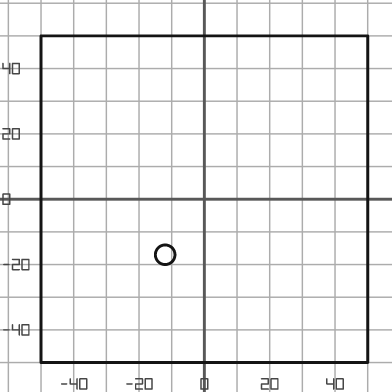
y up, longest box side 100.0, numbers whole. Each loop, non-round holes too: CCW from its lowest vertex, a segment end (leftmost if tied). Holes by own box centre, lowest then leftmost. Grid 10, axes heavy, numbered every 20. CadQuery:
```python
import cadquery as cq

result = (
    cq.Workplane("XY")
    .moveTo(-50.0, -50.0)
    .lineTo(50.0, -50.0)
    .lineTo(50.0, 50.0)
    .lineTo(-50.0, 50.0)
    .close()
    .moveTo(-12.0, -17.0)
    .circle(3.0)
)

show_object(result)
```